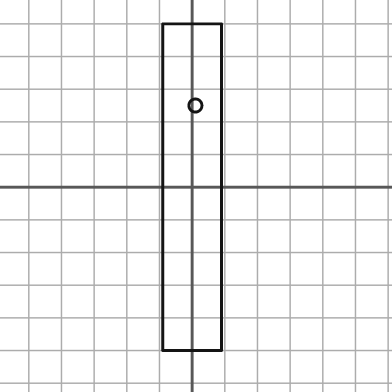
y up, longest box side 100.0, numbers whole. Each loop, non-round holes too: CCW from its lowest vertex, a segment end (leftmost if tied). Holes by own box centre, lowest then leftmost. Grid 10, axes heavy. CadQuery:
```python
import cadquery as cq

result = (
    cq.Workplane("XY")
    .moveTo(-9.0, -50.0)
    .lineTo(9.0, -50.0)
    .lineTo(9.0, 50.0)
    .lineTo(-9.0, 50.0)
    .close()
    .moveTo(1.0, 25.0)
    .circle(2.0)
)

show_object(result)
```